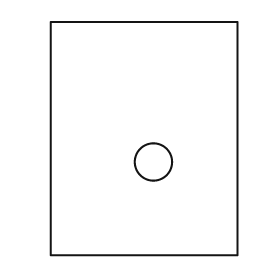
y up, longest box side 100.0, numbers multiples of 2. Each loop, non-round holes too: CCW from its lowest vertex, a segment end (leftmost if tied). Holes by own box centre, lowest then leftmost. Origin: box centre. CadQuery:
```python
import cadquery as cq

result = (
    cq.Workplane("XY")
    .moveTo(-40.0, -50.0)
    .lineTo(40.0, -50.0)
    .lineTo(40.0, 50.0)
    .lineTo(-40.0, 50.0)
    .close()
    .moveTo(4.0, -10.0)
    .circle(8.0)
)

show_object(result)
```